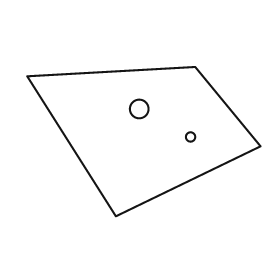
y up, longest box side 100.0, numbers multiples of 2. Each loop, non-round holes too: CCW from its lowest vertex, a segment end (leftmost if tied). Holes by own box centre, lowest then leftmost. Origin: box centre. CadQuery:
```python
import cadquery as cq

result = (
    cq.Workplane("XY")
    .moveTo(-12.0, -32.0)
    .lineTo(50.0, -2.0)
    .lineTo(22.0, 32.0)
    .lineTo(-50.0, 28.0)
    .close()
    .moveTo(20.0, 2.0)
    .circle(2.0)
    .moveTo(-2.0, 14.0)
    .circle(4.0)
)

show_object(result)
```